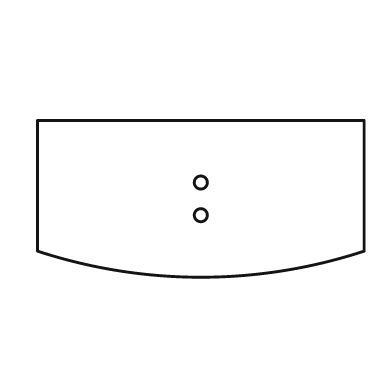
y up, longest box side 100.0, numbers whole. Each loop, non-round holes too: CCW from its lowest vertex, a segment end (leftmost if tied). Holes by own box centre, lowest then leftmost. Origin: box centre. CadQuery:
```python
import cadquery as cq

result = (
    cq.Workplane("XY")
    .moveTo(-50.0, -16.0)
    .threePointArc((0.0, -24.0), (50.0, -16.0))
    .lineTo(50.0, 24.0)
    .lineTo(-50.0, 24.0)
    .close()
    .moveTo(0.0, -5.0)
    .circle(2.0)
    .moveTo(0.0, 5.0)
    .circle(2.0)
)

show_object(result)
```